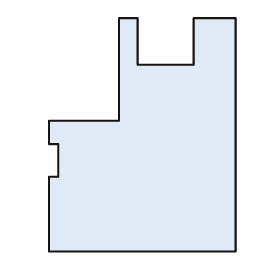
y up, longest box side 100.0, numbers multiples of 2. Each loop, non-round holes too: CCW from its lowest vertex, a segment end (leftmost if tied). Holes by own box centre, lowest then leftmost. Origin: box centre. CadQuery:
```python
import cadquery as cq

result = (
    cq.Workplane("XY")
    .moveTo(-40.0, -50.0)
    .lineTo(40.0, -50.0)
    .lineTo(40.0, 50.0)
    .lineTo(22.0, 50.0)
    .lineTo(22.0, 30.0)
    .lineTo(-2.0, 30.0)
    .lineTo(-2.0, 50.0)
    .lineTo(-10.0, 50.0)
    .lineTo(-10.0, 6.0)
    .lineTo(-40.0, 6.0)
    .lineTo(-40.0, -4.0)
    .lineTo(-36.0, -4.0)
    .lineTo(-36.0, -18.0)
    .lineTo(-40.0, -18.0)
    .close()
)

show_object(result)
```